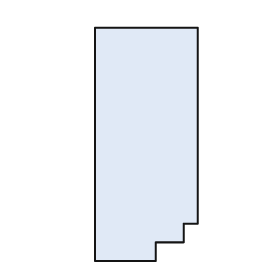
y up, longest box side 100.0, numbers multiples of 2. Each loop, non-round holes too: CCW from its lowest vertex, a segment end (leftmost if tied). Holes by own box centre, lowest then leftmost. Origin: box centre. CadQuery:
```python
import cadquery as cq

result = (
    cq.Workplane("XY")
    .moveTo(-22.0, -50.0)
    .lineTo(4.0, -50.0)
    .lineTo(4.0, -42.0)
    .lineTo(16.0, -42.0)
    .lineTo(16.0, -34.0)
    .lineTo(22.0, -34.0)
    .lineTo(22.0, 50.0)
    .lineTo(-22.0, 50.0)
    .close()
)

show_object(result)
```